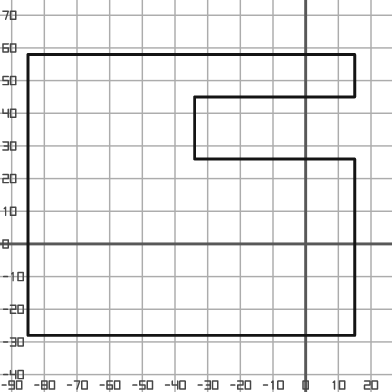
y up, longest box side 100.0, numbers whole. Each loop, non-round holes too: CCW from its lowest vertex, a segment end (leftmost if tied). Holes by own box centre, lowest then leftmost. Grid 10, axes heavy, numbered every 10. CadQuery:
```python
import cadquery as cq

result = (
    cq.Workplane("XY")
    .moveTo(-85.0, -28.0)
    .lineTo(15.0, -28.0)
    .lineTo(15.0, 26.0)
    .lineTo(-34.0, 26.0)
    .lineTo(-34.0, 45.0)
    .lineTo(15.0, 45.0)
    .lineTo(15.0, 58.0)
    .lineTo(-85.0, 58.0)
    .close()
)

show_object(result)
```